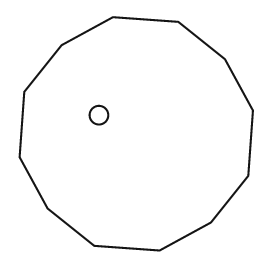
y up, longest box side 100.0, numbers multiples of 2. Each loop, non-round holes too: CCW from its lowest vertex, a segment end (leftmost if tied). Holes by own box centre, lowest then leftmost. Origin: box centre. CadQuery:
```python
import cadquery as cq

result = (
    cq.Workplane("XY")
    .moveTo(10.0, -50.0)
    .lineTo(32.0, -38.0)
    .lineTo(48.0, -18.0)
    .lineTo(50.0, 10.0)
    .lineTo(38.0, 32.0)
    .lineTo(18.0, 48.0)
    .lineTo(-10.0, 50.0)
    .lineTo(-32.0, 38.0)
    .lineTo(-48.0, 18.0)
    .lineTo(-50.0, -10.0)
    .lineTo(-38.0, -32.0)
    .lineTo(-18.0, -48.0)
    .close()
    .moveTo(-16.0, 8.0)
    .circle(4.0)
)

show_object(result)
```